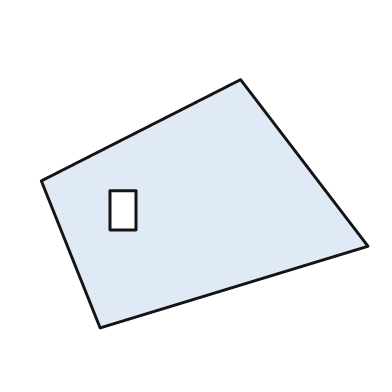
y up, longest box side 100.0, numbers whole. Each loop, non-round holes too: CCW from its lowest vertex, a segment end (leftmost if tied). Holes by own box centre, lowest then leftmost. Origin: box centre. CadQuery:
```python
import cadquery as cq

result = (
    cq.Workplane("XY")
    .moveTo(-32.0, -38.0)
    .lineTo(50.0, -13.0)
    .lineTo(11.0, 38.0)
    .lineTo(-50.0, 7.0)
    .close()
    .moveTo(-29.0, -8.0)
    .lineTo(-21.0, -8.0)
    .lineTo(-21.0, 4.0)
    .lineTo(-29.0, 4.0)
    .close()
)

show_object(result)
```